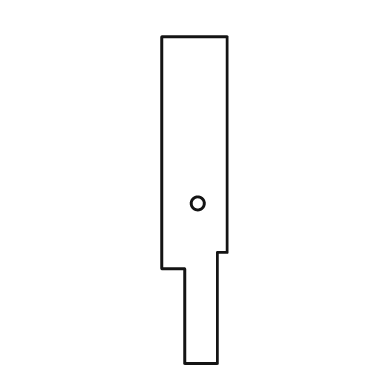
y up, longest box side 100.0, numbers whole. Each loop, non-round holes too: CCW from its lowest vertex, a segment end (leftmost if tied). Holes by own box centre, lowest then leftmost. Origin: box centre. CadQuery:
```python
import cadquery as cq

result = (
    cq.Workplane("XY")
    .moveTo(-3.0, -50.0)
    .lineTo(7.0, -50.0)
    .lineTo(7.0, -16.0)
    .lineTo(10.0, -16.0)
    .lineTo(10.0, 50.0)
    .lineTo(-10.0, 50.0)
    .lineTo(-10.0, -21.0)
    .lineTo(-3.0, -21.0)
    .close()
    .moveTo(1.0, -1.0)
    .circle(2.0)
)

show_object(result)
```